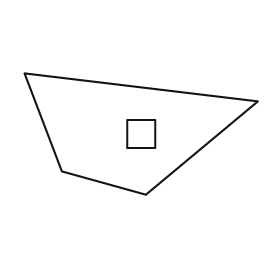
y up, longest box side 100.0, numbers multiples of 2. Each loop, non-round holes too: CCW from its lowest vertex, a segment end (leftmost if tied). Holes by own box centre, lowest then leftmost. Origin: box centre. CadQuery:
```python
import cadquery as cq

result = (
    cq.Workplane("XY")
    .moveTo(2.0, -26.0)
    .lineTo(50.0, 14.0)
    .lineTo(-50.0, 26.0)
    .lineTo(-34.0, -16.0)
    .close()
    .moveTo(-6.0, -6.0)
    .lineTo(6.0, -6.0)
    .lineTo(6.0, 6.0)
    .lineTo(-6.0, 6.0)
    .close()
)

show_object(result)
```